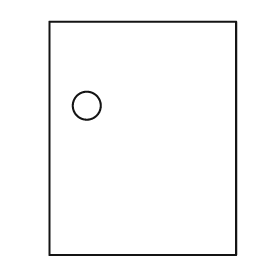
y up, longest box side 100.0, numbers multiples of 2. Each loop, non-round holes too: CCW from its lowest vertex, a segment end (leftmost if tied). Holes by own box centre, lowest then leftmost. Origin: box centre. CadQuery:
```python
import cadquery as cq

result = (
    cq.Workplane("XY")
    .moveTo(-40.0, -50.0)
    .lineTo(40.0, -50.0)
    .lineTo(40.0, 50.0)
    .lineTo(-40.0, 50.0)
    .close()
    .moveTo(-24.0, 14.0)
    .circle(6.0)
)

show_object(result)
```